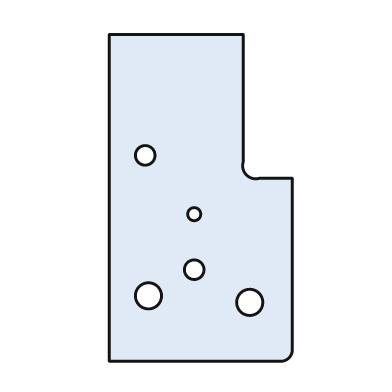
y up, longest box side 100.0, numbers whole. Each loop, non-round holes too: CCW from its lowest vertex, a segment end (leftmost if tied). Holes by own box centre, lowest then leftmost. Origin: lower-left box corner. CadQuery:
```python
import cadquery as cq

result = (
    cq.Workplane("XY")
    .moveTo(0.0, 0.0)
    .lineTo(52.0, 0.0)
    .threePointArc((55.0, 1.0), (56.0, 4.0))
    .lineTo(56.0, 56.0)
    .lineTo(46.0, 56.0)
    .threePointArc((42.0, 57.0), (41.0, 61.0))
    .lineTo(41.0, 100.0)
    .lineTo(0.0, 100.0)
    .close()
    .moveTo(43.0, 18.0)
    .circle(4.0)
    .moveTo(12.0, 20.0)
    .circle(4.0)
    .moveTo(26.0, 28.0)
    .circle(3.0)
    .moveTo(26.0, 45.0)
    .circle(2.0)
    .moveTo(11.0, 63.0)
    .circle(3.0)
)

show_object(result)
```